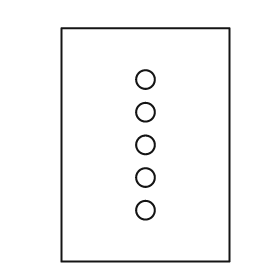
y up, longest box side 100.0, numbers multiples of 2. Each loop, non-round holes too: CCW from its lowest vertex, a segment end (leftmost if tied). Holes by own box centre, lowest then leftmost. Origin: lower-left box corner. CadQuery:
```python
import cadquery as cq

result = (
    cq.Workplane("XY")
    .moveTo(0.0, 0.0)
    .lineTo(72.0, 0.0)
    .lineTo(72.0, 100.0)
    .lineTo(0.0, 100.0)
    .close()
    .moveTo(36.0, 22.0)
    .circle(4.0)
    .moveTo(36.0, 36.0)
    .circle(4.0)
    .moveTo(36.0, 50.0)
    .circle(4.0)
    .moveTo(36.0, 64.0)
    .circle(4.0)
    .moveTo(36.0, 78.0)
    .circle(4.0)
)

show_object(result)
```